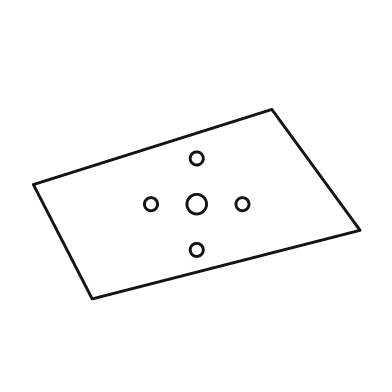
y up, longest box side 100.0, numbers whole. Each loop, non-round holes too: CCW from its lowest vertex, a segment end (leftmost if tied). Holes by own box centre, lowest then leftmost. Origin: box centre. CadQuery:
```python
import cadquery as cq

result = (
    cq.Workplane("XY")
    .moveTo(-32.0, -29.0)
    .lineTo(50.0, -8.0)
    .lineTo(23.0, 29.0)
    .lineTo(-50.0, 6.0)
    .close()
    .moveTo(0.0, -14.0)
    .circle(2.0)
    .moveTo(-14.0, 0.0)
    .circle(2.0)
    .moveTo(0.0, 0.0)
    .circle(3.0)
    .moveTo(14.0, 0.0)
    .circle(2.0)
    .moveTo(0.0, 14.0)
    .circle(2.0)
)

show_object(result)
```